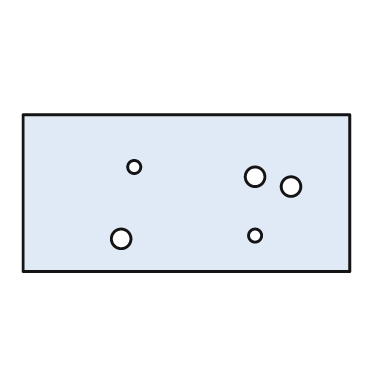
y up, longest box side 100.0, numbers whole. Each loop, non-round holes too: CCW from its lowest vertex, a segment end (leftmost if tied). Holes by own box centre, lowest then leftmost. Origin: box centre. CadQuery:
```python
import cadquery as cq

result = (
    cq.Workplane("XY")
    .moveTo(-50.0, -24.0)
    .lineTo(50.0, -24.0)
    .lineTo(50.0, 24.0)
    .lineTo(-50.0, 24.0)
    .close()
    .moveTo(-20.0, -14.0)
    .circle(3.0)
    .moveTo(21.0, -13.0)
    .circle(2.0)
    .moveTo(32.0, 2.0)
    .circle(3.0)
    .moveTo(21.0, 5.0)
    .circle(3.0)
    .moveTo(-16.0, 8.0)
    .circle(2.0)
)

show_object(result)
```